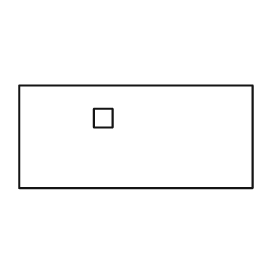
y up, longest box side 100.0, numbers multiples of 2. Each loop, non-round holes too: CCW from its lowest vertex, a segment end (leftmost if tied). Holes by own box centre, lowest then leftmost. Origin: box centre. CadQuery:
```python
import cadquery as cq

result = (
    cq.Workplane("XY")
    .moveTo(-50.0, -22.0)
    .lineTo(50.0, -22.0)
    .lineTo(50.0, 22.0)
    .lineTo(-50.0, 22.0)
    .close()
    .moveTo(-18.0, 4.0)
    .lineTo(-10.0, 4.0)
    .lineTo(-10.0, 12.0)
    .lineTo(-18.0, 12.0)
    .close()
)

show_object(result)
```